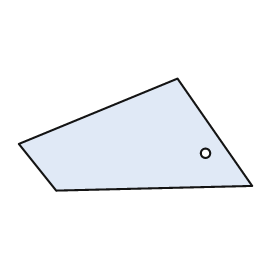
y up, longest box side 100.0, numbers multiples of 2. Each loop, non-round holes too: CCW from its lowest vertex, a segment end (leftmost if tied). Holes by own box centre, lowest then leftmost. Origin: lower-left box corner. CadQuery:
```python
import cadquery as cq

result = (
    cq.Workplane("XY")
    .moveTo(16.0, 0.0)
    .lineTo(100.0, 2.0)
    .lineTo(68.0, 48.0)
    .lineTo(0.0, 20.0)
    .close()
    .moveTo(80.0, 16.0)
    .circle(2.0)
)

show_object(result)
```